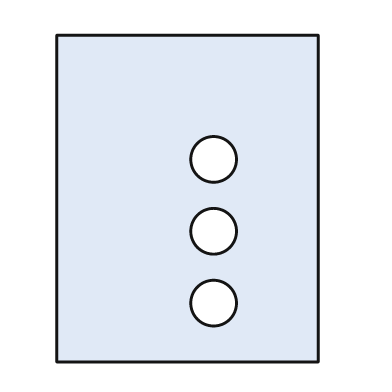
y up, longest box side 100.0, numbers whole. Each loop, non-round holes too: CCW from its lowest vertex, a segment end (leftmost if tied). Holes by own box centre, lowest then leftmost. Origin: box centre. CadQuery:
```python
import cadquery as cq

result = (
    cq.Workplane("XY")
    .moveTo(-40.0, -50.0)
    .lineTo(40.0, -50.0)
    .lineTo(40.0, 50.0)
    .lineTo(-40.0, 50.0)
    .close()
    .moveTo(8.0, -32.0)
    .circle(7.0)
    .moveTo(8.0, -10.0)
    .circle(7.0)
    .moveTo(8.0, 12.0)
    .circle(7.0)
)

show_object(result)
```